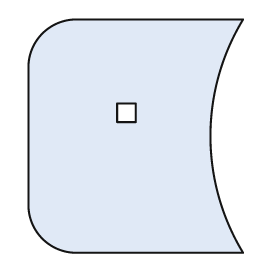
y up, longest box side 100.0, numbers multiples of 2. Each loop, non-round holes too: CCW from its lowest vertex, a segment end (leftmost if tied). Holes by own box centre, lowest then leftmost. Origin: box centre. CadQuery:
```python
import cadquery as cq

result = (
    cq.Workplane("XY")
    .moveTo(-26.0, -50.0)
    .lineTo(46.0, -50.0)
    .threePointArc((32.0, 0.0), (46.0, 50.0))
    .lineTo(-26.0, 50.0)
    .threePointArc((-40.0, 44.0), (-46.0, 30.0))
    .lineTo(-46.0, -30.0)
    .threePointArc((-40.0, -44.0), (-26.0, -50.0))
    .close()
    .moveTo(-8.0, 6.0)
    .lineTo(0.0, 6.0)
    .lineTo(0.0, 14.0)
    .lineTo(-8.0, 14.0)
    .close()
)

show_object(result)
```